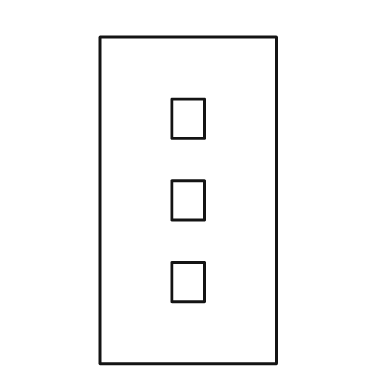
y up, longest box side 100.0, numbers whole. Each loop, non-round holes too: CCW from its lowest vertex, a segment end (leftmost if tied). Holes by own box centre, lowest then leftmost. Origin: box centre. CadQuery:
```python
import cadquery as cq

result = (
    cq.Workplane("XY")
    .moveTo(-27.0, -50.0)
    .lineTo(27.0, -50.0)
    .lineTo(27.0, 50.0)
    .lineTo(-27.0, 50.0)
    .close()
    .moveTo(-5.0, -31.0)
    .lineTo(5.0, -31.0)
    .lineTo(5.0, -19.0)
    .lineTo(-5.0, -19.0)
    .close()
    .moveTo(-5.0, -6.0)
    .lineTo(5.0, -6.0)
    .lineTo(5.0, 6.0)
    .lineTo(-5.0, 6.0)
    .close()
    .moveTo(-5.0, 19.0)
    .lineTo(5.0, 19.0)
    .lineTo(5.0, 31.0)
    .lineTo(-5.0, 31.0)
    .close()
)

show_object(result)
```